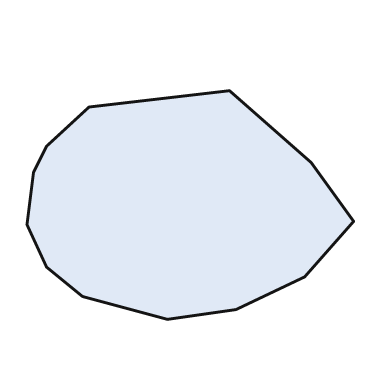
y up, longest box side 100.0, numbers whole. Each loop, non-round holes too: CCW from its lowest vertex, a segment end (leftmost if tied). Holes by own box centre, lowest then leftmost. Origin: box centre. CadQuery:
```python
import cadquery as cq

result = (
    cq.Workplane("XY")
    .moveTo(-7.0, -35.0)
    .lineTo(14.0, -32.0)
    .lineTo(35.0, -22.0)
    .lineTo(50.0, -5.0)
    .lineTo(37.0, 13.0)
    .lineTo(12.0, 35.0)
    .lineTo(-31.0, 30.0)
    .lineTo(-44.0, 18.0)
    .lineTo(-48.0, 10.0)
    .lineTo(-50.0, -6.0)
    .lineTo(-44.0, -19.0)
    .lineTo(-33.0, -28.0)
    .close()
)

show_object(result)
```